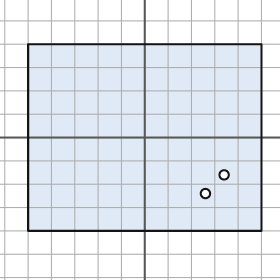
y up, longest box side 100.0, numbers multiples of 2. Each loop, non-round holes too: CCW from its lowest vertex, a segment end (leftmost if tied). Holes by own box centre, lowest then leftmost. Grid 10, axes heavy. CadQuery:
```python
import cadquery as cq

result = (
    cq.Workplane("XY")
    .moveTo(-50.0, -40.0)
    .lineTo(50.0, -40.0)
    .lineTo(50.0, 40.0)
    .lineTo(-50.0, 40.0)
    .close()
    .moveTo(26.0, -24.0)
    .circle(2.0)
    .moveTo(34.0, -16.0)
    .circle(2.0)
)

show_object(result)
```